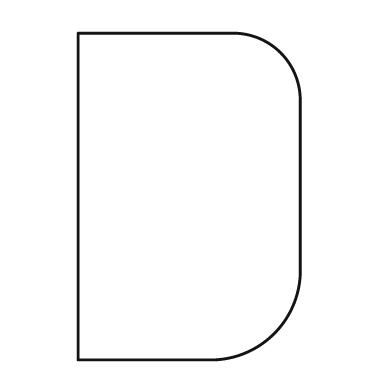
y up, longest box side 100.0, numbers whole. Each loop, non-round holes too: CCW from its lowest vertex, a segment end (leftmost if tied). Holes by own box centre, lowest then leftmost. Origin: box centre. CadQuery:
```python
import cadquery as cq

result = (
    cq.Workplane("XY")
    .moveTo(-34.0, -50.0)
    .lineTo(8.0, -50.0)
    .threePointArc((26.0, -42.0), (34.0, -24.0))
    .lineTo(34.0, 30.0)
    .threePointArc((28.0, 44.0), (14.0, 50.0))
    .lineTo(-34.0, 50.0)
    .close()
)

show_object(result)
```